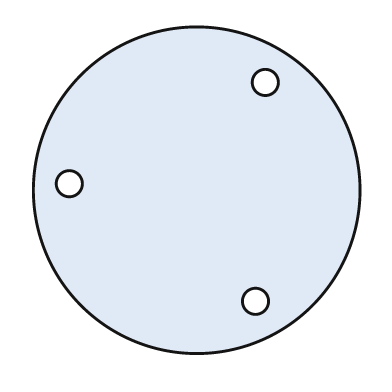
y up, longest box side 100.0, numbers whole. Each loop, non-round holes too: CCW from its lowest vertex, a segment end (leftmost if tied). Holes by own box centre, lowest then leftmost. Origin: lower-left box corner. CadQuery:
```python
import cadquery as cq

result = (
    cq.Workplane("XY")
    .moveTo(50.0, 50.0)
    .circle(50.0)
    .moveTo(68.0, 16.0)
    .circle(4.0)
    .moveTo(11.0, 52.0)
    .circle(4.0)
    .moveTo(71.0, 83.0)
    .circle(4.0)
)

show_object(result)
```